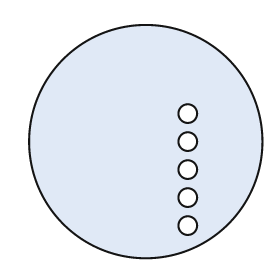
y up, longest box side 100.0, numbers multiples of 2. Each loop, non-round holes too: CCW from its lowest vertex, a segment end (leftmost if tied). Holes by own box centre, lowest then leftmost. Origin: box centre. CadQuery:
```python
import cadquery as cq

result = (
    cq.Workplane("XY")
    .moveTo(0.0, 0.0)
    .circle(50.0)
    .moveTo(18.0, -36.0)
    .circle(4.0)
    .moveTo(18.0, -24.0)
    .circle(4.0)
    .moveTo(18.0, -12.0)
    .circle(4.0)
    .moveTo(18.0, 0.0)
    .circle(4.0)
    .moveTo(18.0, 12.0)
    .circle(4.0)
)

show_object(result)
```